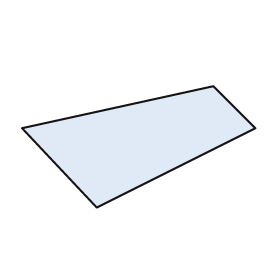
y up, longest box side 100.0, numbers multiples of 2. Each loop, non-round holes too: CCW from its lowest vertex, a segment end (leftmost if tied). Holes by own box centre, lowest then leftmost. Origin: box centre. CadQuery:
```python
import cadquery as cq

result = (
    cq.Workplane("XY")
    .moveTo(-18.0, -26.0)
    .lineTo(50.0, 8.0)
    .lineTo(32.0, 26.0)
    .lineTo(-50.0, 8.0)
    .close()
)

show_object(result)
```